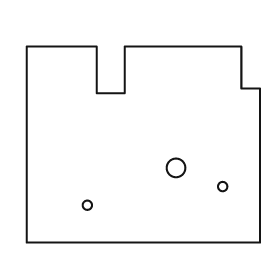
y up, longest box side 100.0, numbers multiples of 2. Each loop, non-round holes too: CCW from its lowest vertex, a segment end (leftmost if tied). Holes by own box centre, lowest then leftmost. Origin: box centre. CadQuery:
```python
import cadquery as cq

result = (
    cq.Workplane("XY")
    .moveTo(-50.0, -42.0)
    .lineTo(50.0, -42.0)
    .lineTo(50.0, 24.0)
    .lineTo(42.0, 24.0)
    .lineTo(42.0, 42.0)
    .lineTo(-8.0, 42.0)
    .lineTo(-8.0, 22.0)
    .lineTo(-20.0, 22.0)
    .lineTo(-20.0, 42.0)
    .lineTo(-50.0, 42.0)
    .close()
    .moveTo(-24.0, -26.0)
    .circle(2.0)
    .moveTo(34.0, -18.0)
    .circle(2.0)
    .moveTo(14.0, -10.0)
    .circle(4.0)
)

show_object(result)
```